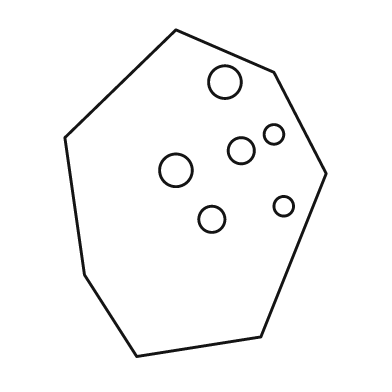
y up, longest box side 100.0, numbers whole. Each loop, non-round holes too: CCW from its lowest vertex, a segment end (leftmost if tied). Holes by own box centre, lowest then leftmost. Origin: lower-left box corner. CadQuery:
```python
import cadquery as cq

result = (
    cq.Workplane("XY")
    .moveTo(22.0, 0.0)
    .lineTo(60.0, 6.0)
    .lineTo(80.0, 56.0)
    .lineTo(64.0, 87.0)
    .lineTo(34.0, 100.0)
    .lineTo(0.0, 67.0)
    .lineTo(6.0, 25.0)
    .close()
    .moveTo(45.0, 42.0)
    .circle(4.0)
    .moveTo(67.0, 46.0)
    .circle(3.0)
    .moveTo(34.0, 57.0)
    .circle(5.0)
    .moveTo(54.0, 63.0)
    .circle(4.0)
    .moveTo(64.0, 68.0)
    .circle(3.0)
    .moveTo(49.0, 84.0)
    .circle(5.0)
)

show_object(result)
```